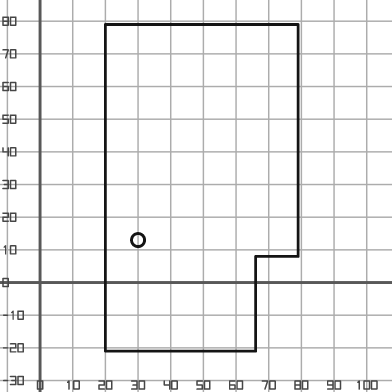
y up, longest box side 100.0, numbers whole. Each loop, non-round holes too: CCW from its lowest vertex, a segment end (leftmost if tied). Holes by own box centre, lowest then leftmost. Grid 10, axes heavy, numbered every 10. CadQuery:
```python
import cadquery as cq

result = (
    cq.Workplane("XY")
    .moveTo(20.0, -21.0)
    .lineTo(66.0, -21.0)
    .lineTo(66.0, 8.0)
    .lineTo(79.0, 8.0)
    .lineTo(79.0, 79.0)
    .lineTo(20.0, 79.0)
    .close()
    .moveTo(30.0, 13.0)
    .circle(2.0)
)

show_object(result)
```